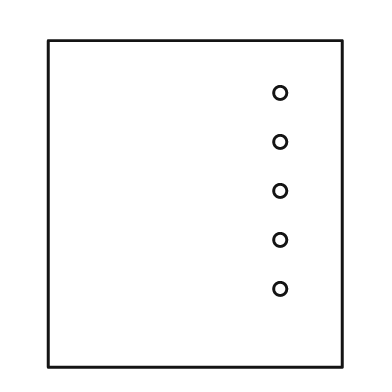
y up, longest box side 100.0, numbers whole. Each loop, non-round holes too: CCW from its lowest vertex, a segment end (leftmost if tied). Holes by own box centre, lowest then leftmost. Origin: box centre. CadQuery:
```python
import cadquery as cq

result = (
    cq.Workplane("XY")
    .moveTo(-45.0, -50.0)
    .lineTo(45.0, -50.0)
    .lineTo(45.0, 50.0)
    .lineTo(-45.0, 50.0)
    .close()
    .moveTo(26.0, -26.0)
    .circle(2.0)
    .moveTo(26.0, -11.0)
    .circle(2.0)
    .moveTo(26.0, 4.0)
    .circle(2.0)
    .moveTo(26.0, 19.0)
    .circle(2.0)
    .moveTo(26.0, 34.0)
    .circle(2.0)
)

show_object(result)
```